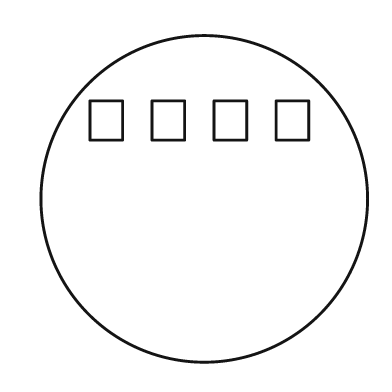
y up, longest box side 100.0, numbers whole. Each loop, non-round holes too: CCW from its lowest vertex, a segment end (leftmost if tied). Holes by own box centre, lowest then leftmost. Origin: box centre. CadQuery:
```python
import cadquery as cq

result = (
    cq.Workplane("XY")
    .moveTo(0.0, 0.0)
    .circle(50.0)
    .moveTo(-35.0, 18.0)
    .lineTo(-25.0, 18.0)
    .lineTo(-25.0, 30.0)
    .lineTo(-35.0, 30.0)
    .close()
    .moveTo(-16.0, 18.0)
    .lineTo(-6.0, 18.0)
    .lineTo(-6.0, 30.0)
    .lineTo(-16.0, 30.0)
    .close()
    .moveTo(3.0, 18.0)
    .lineTo(13.0, 18.0)
    .lineTo(13.0, 30.0)
    .lineTo(3.0, 30.0)
    .close()
    .moveTo(22.0, 18.0)
    .lineTo(32.0, 18.0)
    .lineTo(32.0, 30.0)
    .lineTo(22.0, 30.0)
    .close()
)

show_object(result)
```